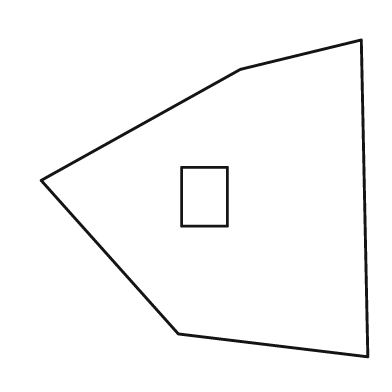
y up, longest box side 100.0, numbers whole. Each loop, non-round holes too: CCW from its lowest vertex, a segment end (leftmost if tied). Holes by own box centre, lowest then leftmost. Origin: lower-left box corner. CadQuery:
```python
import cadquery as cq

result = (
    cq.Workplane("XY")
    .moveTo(100.0, 0.0)
    .lineTo(98.0, 97.0)
    .lineTo(61.0, 88.0)
    .lineTo(0.0, 54.0)
    .lineTo(42.0, 7.0)
    .close()
    .moveTo(43.0, 40.0)
    .lineTo(57.0, 40.0)
    .lineTo(57.0, 58.0)
    .lineTo(43.0, 58.0)
    .close()
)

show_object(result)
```